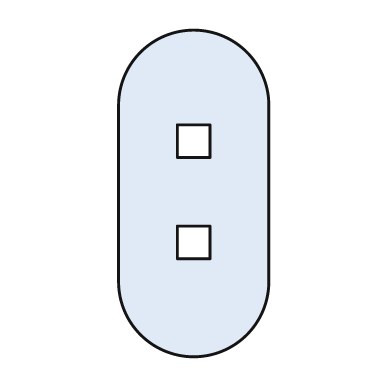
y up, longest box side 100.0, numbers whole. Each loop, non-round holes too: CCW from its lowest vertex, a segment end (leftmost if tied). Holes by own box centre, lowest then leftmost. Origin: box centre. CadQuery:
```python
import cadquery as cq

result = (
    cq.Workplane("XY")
    .moveTo(-23.0, -27.0)
    .threePointArc((0.0, -50.0), (23.0, -27.0))
    .lineTo(23.0, 27.0)
    .threePointArc((0.0, 50.0), (-23.0, 27.0))
    .close()
    .moveTo(-5.0, -20.0)
    .lineTo(5.0, -20.0)
    .lineTo(5.0, -10.0)
    .lineTo(-5.0, -10.0)
    .close()
    .moveTo(-5.0, 11.0)
    .lineTo(5.0, 11.0)
    .lineTo(5.0, 21.0)
    .lineTo(-5.0, 21.0)
    .close()
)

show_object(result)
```